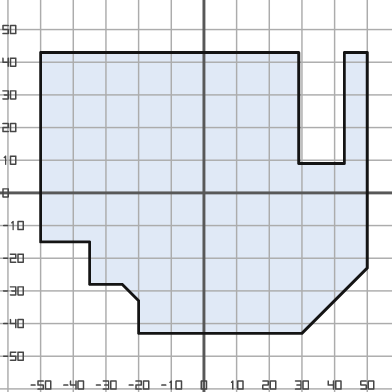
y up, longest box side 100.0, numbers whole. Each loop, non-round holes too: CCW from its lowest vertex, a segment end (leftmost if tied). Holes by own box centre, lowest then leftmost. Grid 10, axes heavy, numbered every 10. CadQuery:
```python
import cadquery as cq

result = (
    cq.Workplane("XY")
    .moveTo(-20.0, -43.0)
    .lineTo(30.0, -43.0)
    .lineTo(50.0, -23.0)
    .lineTo(50.0, 43.0)
    .lineTo(43.0, 43.0)
    .lineTo(43.0, 9.0)
    .lineTo(29.0, 9.0)
    .lineTo(29.0, 43.0)
    .lineTo(-50.0, 43.0)
    .lineTo(-50.0, -15.0)
    .lineTo(-35.0, -15.0)
    .lineTo(-35.0, -28.0)
    .lineTo(-25.0, -28.0)
    .lineTo(-20.0, -33.0)
    .close()
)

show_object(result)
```